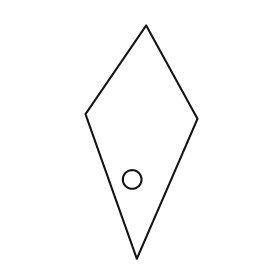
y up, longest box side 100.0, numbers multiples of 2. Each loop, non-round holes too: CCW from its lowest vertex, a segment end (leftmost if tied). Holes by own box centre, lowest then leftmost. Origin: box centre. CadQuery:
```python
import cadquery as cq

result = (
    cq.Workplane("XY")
    .moveTo(-2.0, -50.0)
    .lineTo(24.0, 10.0)
    .lineTo(2.0, 50.0)
    .lineTo(-24.0, 12.0)
    .close()
    .moveTo(-4.0, -16.0)
    .circle(4.0)
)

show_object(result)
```